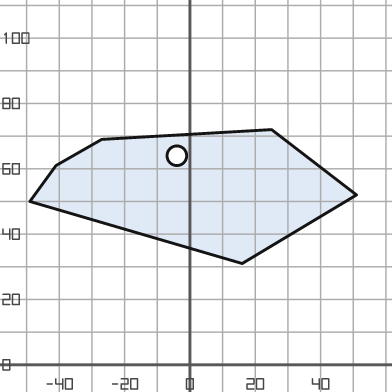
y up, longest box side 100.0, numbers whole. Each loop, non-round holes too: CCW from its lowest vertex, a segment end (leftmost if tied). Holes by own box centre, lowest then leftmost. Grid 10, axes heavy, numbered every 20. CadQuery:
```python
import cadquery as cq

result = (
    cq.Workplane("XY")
    .moveTo(16.0, 31.0)
    .lineTo(51.0, 52.0)
    .lineTo(25.0, 72.0)
    .lineTo(-27.0, 69.0)
    .lineTo(-41.0, 61.0)
    .lineTo(-49.0, 50.0)
    .close()
    .moveTo(-4.0, 64.0)
    .circle(3.0)
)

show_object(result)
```